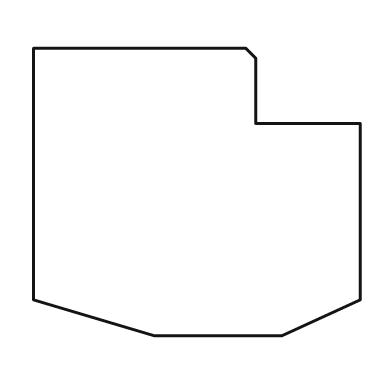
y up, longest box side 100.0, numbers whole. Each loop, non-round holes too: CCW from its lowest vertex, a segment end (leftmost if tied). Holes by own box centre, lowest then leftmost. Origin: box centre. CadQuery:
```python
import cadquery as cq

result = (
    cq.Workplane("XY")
    .moveTo(-13.0, -44.0)
    .lineTo(26.0, -44.0)
    .lineTo(50.0, -33.0)
    .lineTo(50.0, 21.0)
    .lineTo(18.0, 21.0)
    .lineTo(18.0, 41.0)
    .lineTo(15.0, 44.0)
    .lineTo(-50.0, 44.0)
    .lineTo(-50.0, -33.0)
    .close()
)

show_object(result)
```